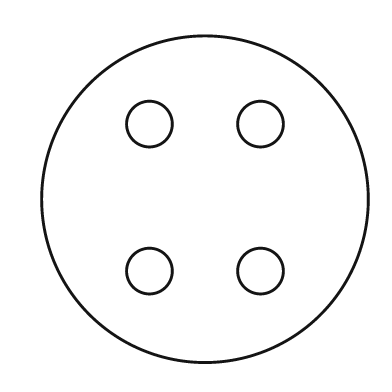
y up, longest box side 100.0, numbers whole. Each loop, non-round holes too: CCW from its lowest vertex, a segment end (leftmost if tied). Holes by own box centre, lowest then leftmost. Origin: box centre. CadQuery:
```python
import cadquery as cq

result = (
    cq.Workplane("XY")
    .moveTo(0.0, 0.0)
    .circle(50.0)
    .moveTo(-17.0, -22.0)
    .circle(7.0)
    .moveTo(17.0, -22.0)
    .circle(7.0)
    .moveTo(-17.0, 23.0)
    .circle(7.0)
    .moveTo(17.0, 23.0)
    .circle(7.0)
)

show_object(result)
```